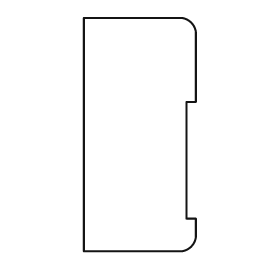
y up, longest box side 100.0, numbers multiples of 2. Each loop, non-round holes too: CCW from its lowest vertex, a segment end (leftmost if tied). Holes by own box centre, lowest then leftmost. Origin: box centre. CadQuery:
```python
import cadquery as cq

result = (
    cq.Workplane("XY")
    .moveTo(-24.0, -50.0)
    .lineTo(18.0, -50.0)
    .threePointArc((22.0, -48.0), (24.0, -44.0))
    .lineTo(24.0, -36.0)
    .lineTo(20.0, -36.0)
    .lineTo(20.0, 14.0)
    .lineTo(24.0, 14.0)
    .lineTo(24.0, 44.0)
    .threePointArc((22.0, 48.0), (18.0, 50.0))
    .lineTo(-24.0, 50.0)
    .close()
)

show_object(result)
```